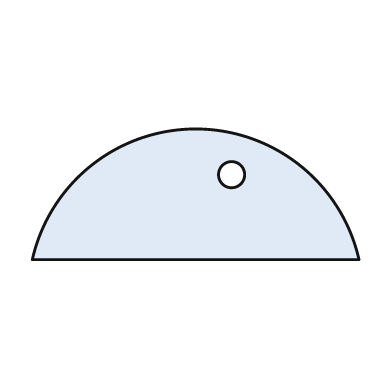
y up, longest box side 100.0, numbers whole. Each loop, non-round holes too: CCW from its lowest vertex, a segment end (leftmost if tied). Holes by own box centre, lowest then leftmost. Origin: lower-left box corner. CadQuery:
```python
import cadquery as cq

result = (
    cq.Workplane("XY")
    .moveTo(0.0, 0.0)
    .lineTo(100.0, 0.0)
    .threePointArc((50.0, 40.0), (0.0, 0.0))
    .close()
    .moveTo(61.0, 26.0)
    .circle(4.0)
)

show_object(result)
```